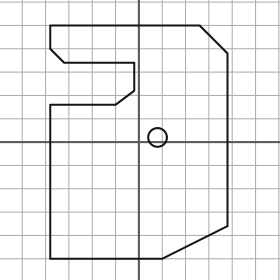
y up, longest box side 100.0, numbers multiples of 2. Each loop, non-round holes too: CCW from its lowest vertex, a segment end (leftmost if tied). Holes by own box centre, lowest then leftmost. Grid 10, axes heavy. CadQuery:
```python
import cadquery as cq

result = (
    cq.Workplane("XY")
    .moveTo(-38.0, -50.0)
    .lineTo(10.0, -50.0)
    .lineTo(38.0, -36.0)
    .lineTo(38.0, 38.0)
    .lineTo(26.0, 50.0)
    .lineTo(-38.0, 50.0)
    .lineTo(-38.0, 40.0)
    .lineTo(-32.0, 34.0)
    .lineTo(-2.0, 34.0)
    .lineTo(-2.0, 22.0)
    .lineTo(-10.0, 16.0)
    .lineTo(-38.0, 16.0)
    .close()
    .moveTo(8.0, 2.0)
    .circle(4.0)
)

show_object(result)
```